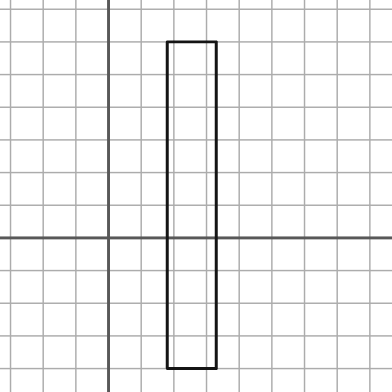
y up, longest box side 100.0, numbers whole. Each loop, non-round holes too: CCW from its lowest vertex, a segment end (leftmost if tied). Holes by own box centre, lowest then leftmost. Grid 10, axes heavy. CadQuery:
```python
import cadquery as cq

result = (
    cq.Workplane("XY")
    .moveTo(18.0, -40.0)
    .lineTo(33.0, -40.0)
    .lineTo(33.0, 60.0)
    .lineTo(18.0, 60.0)
    .close()
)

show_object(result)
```